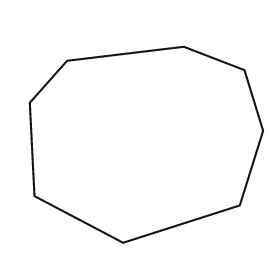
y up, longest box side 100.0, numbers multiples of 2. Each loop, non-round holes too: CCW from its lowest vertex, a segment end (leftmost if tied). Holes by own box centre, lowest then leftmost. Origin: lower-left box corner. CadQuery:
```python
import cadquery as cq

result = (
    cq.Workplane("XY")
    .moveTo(40.0, 0.0)
    .lineTo(90.0, 16.0)
    .lineTo(100.0, 48.0)
    .lineTo(92.0, 74.0)
    .lineTo(66.0, 84.0)
    .lineTo(16.0, 78.0)
    .lineTo(0.0, 60.0)
    .lineTo(2.0, 20.0)
    .close()
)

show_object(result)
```